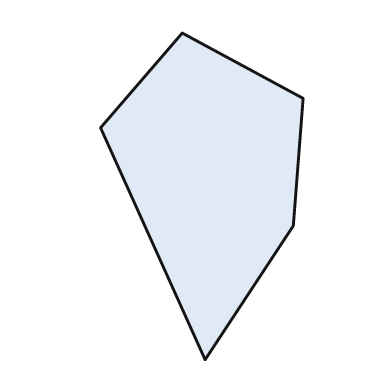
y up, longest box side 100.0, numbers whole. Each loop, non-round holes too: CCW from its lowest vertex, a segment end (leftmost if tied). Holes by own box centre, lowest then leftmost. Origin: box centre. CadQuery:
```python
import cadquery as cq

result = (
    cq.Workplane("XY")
    .moveTo(1.0, -50.0)
    .lineTo(28.0, -9.0)
    .lineTo(31.0, 30.0)
    .lineTo(-6.0, 50.0)
    .lineTo(-31.0, 21.0)
    .close()
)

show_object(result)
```